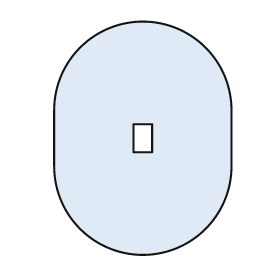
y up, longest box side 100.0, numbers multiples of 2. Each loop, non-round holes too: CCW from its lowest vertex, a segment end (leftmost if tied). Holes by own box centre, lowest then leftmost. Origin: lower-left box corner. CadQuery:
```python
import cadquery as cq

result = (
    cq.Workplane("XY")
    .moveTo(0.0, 38.0)
    .threePointArc((38.0, 0.0), (76.0, 38.0))
    .lineTo(76.0, 62.0)
    .threePointArc((38.0, 100.0), (0.0, 62.0))
    .close()
    .moveTo(34.0, 44.0)
    .lineTo(42.0, 44.0)
    .lineTo(42.0, 56.0)
    .lineTo(34.0, 56.0)
    .close()
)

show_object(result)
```